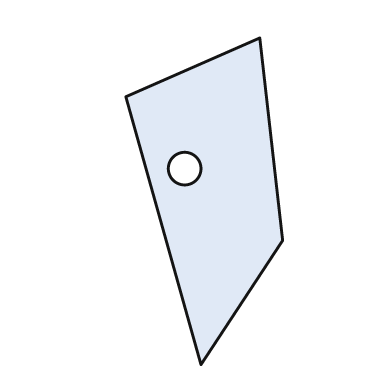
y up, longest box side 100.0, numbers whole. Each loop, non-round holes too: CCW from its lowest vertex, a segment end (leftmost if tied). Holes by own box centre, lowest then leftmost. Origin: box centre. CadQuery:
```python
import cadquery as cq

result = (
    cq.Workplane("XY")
    .moveTo(-1.0, -50.0)
    .lineTo(24.0, -12.0)
    .lineTo(17.0, 50.0)
    .lineTo(-24.0, 32.0)
    .close()
    .moveTo(-6.0, 10.0)
    .circle(5.0)
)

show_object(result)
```